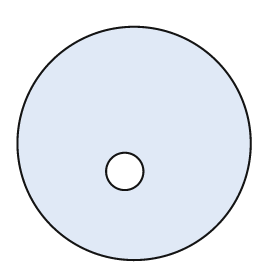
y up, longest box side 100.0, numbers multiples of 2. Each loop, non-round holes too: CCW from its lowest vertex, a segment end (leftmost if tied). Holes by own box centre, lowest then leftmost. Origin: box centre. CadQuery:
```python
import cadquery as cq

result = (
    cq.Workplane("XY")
    .moveTo(0.0, 0.0)
    .circle(50.0)
    .moveTo(-4.0, -12.0)
    .circle(8.0)
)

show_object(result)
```